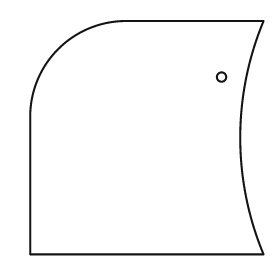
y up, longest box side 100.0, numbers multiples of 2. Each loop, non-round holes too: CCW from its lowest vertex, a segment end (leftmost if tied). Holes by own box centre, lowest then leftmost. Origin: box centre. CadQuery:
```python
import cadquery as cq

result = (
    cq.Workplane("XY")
    .moveTo(-50.0, -50.0)
    .lineTo(50.0, -50.0)
    .threePointArc((40.0, 0.0), (50.0, 50.0))
    .lineTo(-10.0, 50.0)
    .threePointArc((-38.0, 38.0), (-50.0, 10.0))
    .close()
    .moveTo(32.0, 26.0)
    .circle(2.0)
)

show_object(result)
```